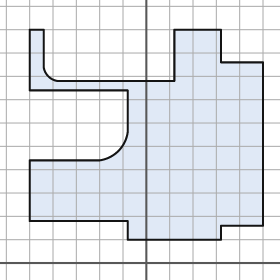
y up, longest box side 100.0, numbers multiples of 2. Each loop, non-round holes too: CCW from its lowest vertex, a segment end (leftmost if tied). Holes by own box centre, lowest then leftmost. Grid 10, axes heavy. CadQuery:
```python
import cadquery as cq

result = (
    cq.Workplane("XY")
    .moveTo(-8.0, 10.0)
    .lineTo(32.0, 10.0)
    .lineTo(32.0, 16.0)
    .lineTo(50.0, 16.0)
    .lineTo(50.0, 86.0)
    .lineTo(32.0, 86.0)
    .lineTo(32.0, 100.0)
    .lineTo(12.0, 100.0)
    .lineTo(12.0, 78.0)
    .lineTo(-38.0, 78.0)
    .threePointArc((-42.0, 80.0), (-44.0, 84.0))
    .lineTo(-44.0, 100.0)
    .lineTo(-50.0, 100.0)
    .lineTo(-50.0, 74.0)
    .lineTo(-8.0, 74.0)
    .lineTo(-8.0, 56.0)
    .threePointArc((-12.0, 48.0), (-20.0, 44.0))
    .lineTo(-50.0, 44.0)
    .lineTo(-50.0, 18.0)
    .lineTo(-8.0, 18.0)
    .close()
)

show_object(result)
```